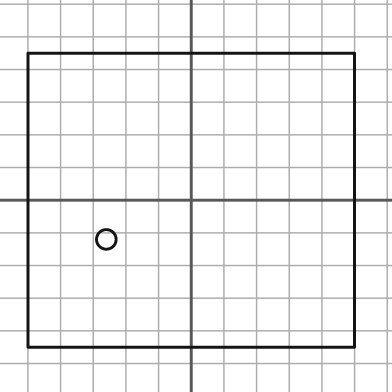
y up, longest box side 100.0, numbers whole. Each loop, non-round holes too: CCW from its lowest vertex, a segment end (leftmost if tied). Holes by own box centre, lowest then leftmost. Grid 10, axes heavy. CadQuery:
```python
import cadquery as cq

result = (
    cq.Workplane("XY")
    .moveTo(-50.0, -45.0)
    .lineTo(50.0, -45.0)
    .lineTo(50.0, 45.0)
    .lineTo(-50.0, 45.0)
    .close()
    .moveTo(-26.0, -12.0)
    .circle(3.0)
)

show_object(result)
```